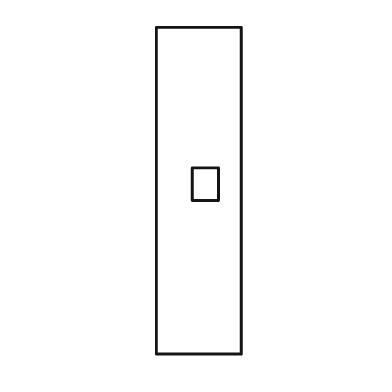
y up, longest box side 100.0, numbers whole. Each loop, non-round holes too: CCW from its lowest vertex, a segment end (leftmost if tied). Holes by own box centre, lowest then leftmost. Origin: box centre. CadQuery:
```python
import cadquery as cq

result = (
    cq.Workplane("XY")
    .moveTo(-13.0, -50.0)
    .lineTo(13.0, -50.0)
    .lineTo(13.0, 50.0)
    .lineTo(-13.0, 50.0)
    .close()
    .moveTo(-2.0, -3.0)
    .lineTo(6.0, -3.0)
    .lineTo(6.0, 7.0)
    .lineTo(-2.0, 7.0)
    .close()
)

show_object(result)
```